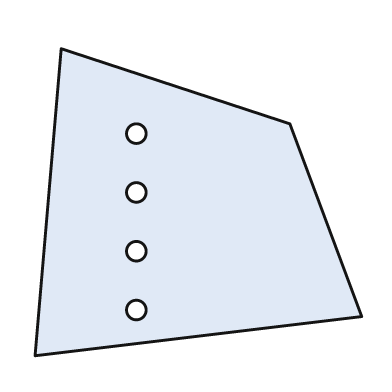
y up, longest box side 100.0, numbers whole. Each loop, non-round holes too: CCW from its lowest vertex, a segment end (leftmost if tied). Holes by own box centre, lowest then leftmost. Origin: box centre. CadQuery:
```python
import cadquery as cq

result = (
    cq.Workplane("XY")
    .moveTo(-50.0, -47.0)
    .lineTo(50.0, -35.0)
    .lineTo(28.0, 24.0)
    .lineTo(-42.0, 47.0)
    .close()
    .moveTo(-19.0, -33.0)
    .circle(3.0)
    .moveTo(-19.0, -15.0)
    .circle(3.0)
    .moveTo(-19.0, 3.0)
    .circle(3.0)
    .moveTo(-19.0, 21.0)
    .circle(3.0)
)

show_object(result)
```